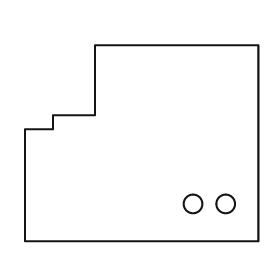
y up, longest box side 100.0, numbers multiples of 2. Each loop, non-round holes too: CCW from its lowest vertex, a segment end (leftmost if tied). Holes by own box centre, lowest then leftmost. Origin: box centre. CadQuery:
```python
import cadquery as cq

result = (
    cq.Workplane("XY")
    .moveTo(-50.0, -42.0)
    .lineTo(50.0, -42.0)
    .lineTo(50.0, 42.0)
    .lineTo(-20.0, 42.0)
    .lineTo(-20.0, 12.0)
    .lineTo(-38.0, 12.0)
    .lineTo(-38.0, 6.0)
    .lineTo(-50.0, 6.0)
    .close()
    .moveTo(22.0, -26.0)
    .circle(4.0)
    .moveTo(36.0, -26.0)
    .circle(4.0)
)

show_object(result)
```